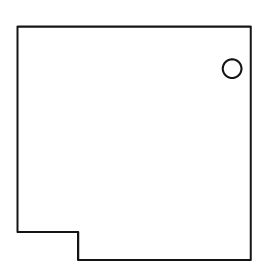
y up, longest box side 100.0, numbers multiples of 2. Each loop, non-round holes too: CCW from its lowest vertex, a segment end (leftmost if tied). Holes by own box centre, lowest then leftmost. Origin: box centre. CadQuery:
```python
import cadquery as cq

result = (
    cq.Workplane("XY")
    .moveTo(-24.0, -50.0)
    .lineTo(50.0, -50.0)
    .lineTo(50.0, 50.0)
    .lineTo(-50.0, 50.0)
    .lineTo(-50.0, -38.0)
    .lineTo(-24.0, -38.0)
    .close()
    .moveTo(42.0, 32.0)
    .circle(4.0)
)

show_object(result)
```